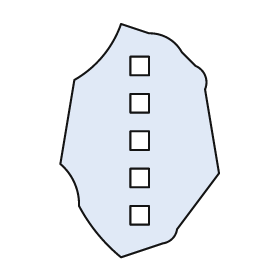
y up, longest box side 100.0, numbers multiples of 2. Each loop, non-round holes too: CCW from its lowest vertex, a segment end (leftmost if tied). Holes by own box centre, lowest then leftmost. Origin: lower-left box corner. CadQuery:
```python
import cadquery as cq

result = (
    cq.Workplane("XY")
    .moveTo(26.0, 0.0)
    .lineTo(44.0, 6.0)
    .threePointArc((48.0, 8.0), (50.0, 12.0))
    .lineTo(68.0, 36.0)
    .lineTo(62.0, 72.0)
    .threePointArc((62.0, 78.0), (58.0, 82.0))
    .lineTo(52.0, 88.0)
    .threePointArc((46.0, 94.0), (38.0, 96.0))
    .lineTo(26.0, 100.0)
    .threePointArc((18.0, 86.0), (6.0, 76.0))
    .lineTo(0.0, 40.0)
    .threePointArc((6.0, 32.0), (8.0, 22.0))
    .threePointArc((16.0, 10.0), (26.0, 0.0))
    .close()
    .moveTo(30.0, 14.0)
    .lineTo(38.0, 14.0)
    .lineTo(38.0, 22.0)
    .lineTo(30.0, 22.0)
    .close()
    .moveTo(30.0, 30.0)
    .lineTo(38.0, 30.0)
    .lineTo(38.0, 38.0)
    .lineTo(30.0, 38.0)
    .close()
    .moveTo(30.0, 46.0)
    .lineTo(38.0, 46.0)
    .lineTo(38.0, 54.0)
    .lineTo(30.0, 54.0)
    .close()
    .moveTo(30.0, 62.0)
    .lineTo(38.0, 62.0)
    .lineTo(38.0, 70.0)
    .lineTo(30.0, 70.0)
    .close()
    .moveTo(30.0, 78.0)
    .lineTo(38.0, 78.0)
    .lineTo(38.0, 86.0)
    .lineTo(30.0, 86.0)
    .close()
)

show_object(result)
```